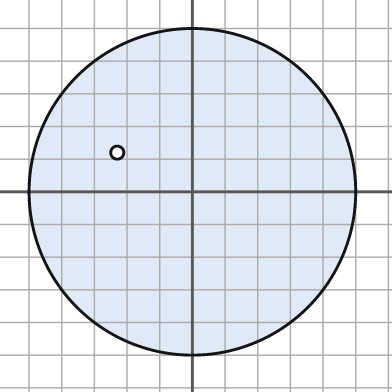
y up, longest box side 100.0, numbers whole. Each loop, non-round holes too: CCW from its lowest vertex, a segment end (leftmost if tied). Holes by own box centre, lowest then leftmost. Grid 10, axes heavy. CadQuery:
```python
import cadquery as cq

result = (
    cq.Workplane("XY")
    .moveTo(0.0, 0.0)
    .circle(50.0)
    .moveTo(-23.0, 12.0)
    .circle(2.0)
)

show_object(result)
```